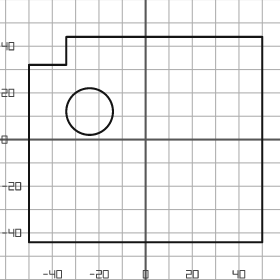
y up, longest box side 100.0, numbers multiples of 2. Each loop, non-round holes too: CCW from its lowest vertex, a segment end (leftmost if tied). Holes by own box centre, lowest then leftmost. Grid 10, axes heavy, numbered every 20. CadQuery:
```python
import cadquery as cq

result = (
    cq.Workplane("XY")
    .moveTo(-50.0, -44.0)
    .lineTo(50.0, -44.0)
    .lineTo(50.0, 44.0)
    .lineTo(-34.0, 44.0)
    .lineTo(-34.0, 32.0)
    .lineTo(-50.0, 32.0)
    .close()
    .moveTo(-24.0, 12.0)
    .circle(10.0)
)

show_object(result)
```